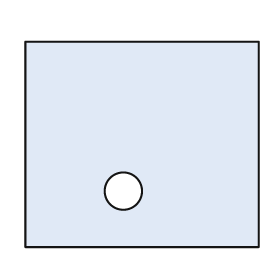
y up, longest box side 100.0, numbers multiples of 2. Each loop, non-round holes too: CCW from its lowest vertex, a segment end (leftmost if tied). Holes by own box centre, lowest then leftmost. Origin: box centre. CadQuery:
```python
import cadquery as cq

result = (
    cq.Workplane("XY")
    .moveTo(-50.0, -44.0)
    .lineTo(50.0, -44.0)
    .lineTo(50.0, 44.0)
    .lineTo(-50.0, 44.0)
    .close()
    .moveTo(-8.0, -20.0)
    .circle(8.0)
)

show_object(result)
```